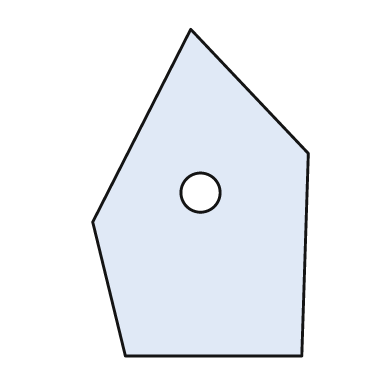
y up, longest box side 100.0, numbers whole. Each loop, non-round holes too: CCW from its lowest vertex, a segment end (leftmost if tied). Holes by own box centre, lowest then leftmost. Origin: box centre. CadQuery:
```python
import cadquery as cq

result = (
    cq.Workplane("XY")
    .moveTo(-23.0, -50.0)
    .lineTo(31.0, -50.0)
    .lineTo(33.0, 12.0)
    .lineTo(-3.0, 50.0)
    .lineTo(-33.0, -9.0)
    .close()
    .moveTo(0.0, 0.0)
    .circle(6.0)
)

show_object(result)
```